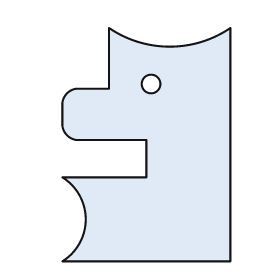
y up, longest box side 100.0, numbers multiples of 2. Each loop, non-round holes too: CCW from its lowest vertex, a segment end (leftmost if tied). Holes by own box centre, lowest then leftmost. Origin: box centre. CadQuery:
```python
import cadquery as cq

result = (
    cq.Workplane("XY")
    .moveTo(-36.0, -50.0)
    .lineTo(36.0, -50.0)
    .lineTo(36.0, 50.0)
    .threePointArc((10.0, 42.0), (-16.0, 50.0))
    .lineTo(-16.0, 24.0)
    .lineTo(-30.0, 24.0)
    .threePointArc((-34.0, 22.0), (-36.0, 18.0))
    .lineTo(-36.0, 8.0)
    .threePointArc((-34.0, 4.0), (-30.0, 2.0))
    .lineTo(0.0, 2.0)
    .lineTo(0.0, -14.0)
    .lineTo(-36.0, -14.0)
    .threePointArc((-26.0, -32.0), (-36.0, -50.0))
    .close()
    .moveTo(2.0, 26.0)
    .circle(4.0)
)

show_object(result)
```